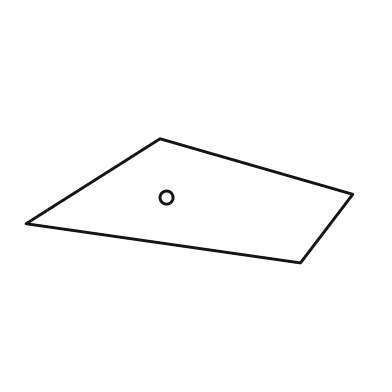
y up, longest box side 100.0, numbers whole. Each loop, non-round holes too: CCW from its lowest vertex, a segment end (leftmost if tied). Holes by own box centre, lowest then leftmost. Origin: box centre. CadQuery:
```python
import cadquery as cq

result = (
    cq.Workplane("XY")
    .moveTo(34.0, -19.0)
    .lineTo(50.0, 2.0)
    .lineTo(-9.0, 19.0)
    .lineTo(-50.0, -7.0)
    .close()
    .moveTo(-7.0, 1.0)
    .circle(2.0)
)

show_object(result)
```